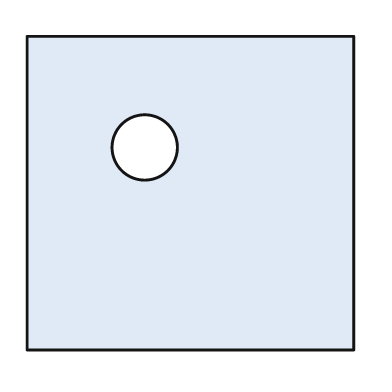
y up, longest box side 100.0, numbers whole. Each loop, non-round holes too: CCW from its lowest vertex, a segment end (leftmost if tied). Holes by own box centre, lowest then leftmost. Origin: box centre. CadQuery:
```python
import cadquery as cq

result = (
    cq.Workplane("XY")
    .moveTo(-50.0, -48.0)
    .lineTo(50.0, -48.0)
    .lineTo(50.0, 48.0)
    .lineTo(-50.0, 48.0)
    .close()
    .moveTo(-14.0, 14.0)
    .circle(10.0)
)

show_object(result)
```